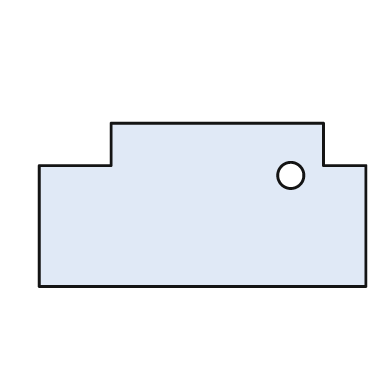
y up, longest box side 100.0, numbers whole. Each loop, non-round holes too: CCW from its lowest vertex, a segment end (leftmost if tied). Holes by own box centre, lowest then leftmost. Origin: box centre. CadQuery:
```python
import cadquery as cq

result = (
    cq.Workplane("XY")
    .moveTo(-50.0, -25.0)
    .lineTo(50.0, -25.0)
    .lineTo(50.0, 12.0)
    .lineTo(37.0, 12.0)
    .lineTo(37.0, 25.0)
    .lineTo(-28.0, 25.0)
    .lineTo(-28.0, 12.0)
    .lineTo(-50.0, 12.0)
    .close()
    .moveTo(27.0, 9.0)
    .circle(4.0)
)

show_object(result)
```